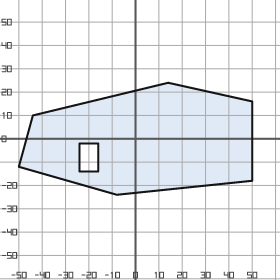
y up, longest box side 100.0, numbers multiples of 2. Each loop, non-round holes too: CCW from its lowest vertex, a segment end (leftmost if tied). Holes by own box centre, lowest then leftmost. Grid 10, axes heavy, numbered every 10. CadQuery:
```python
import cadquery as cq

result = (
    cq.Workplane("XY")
    .moveTo(-8.0, -24.0)
    .lineTo(50.0, -18.0)
    .lineTo(50.0, 16.0)
    .lineTo(14.0, 24.0)
    .lineTo(-44.0, 10.0)
    .lineTo(-50.0, -12.0)
    .close()
    .moveTo(-24.0, -14.0)
    .lineTo(-16.0, -14.0)
    .lineTo(-16.0, -2.0)
    .lineTo(-24.0, -2.0)
    .close()
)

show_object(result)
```